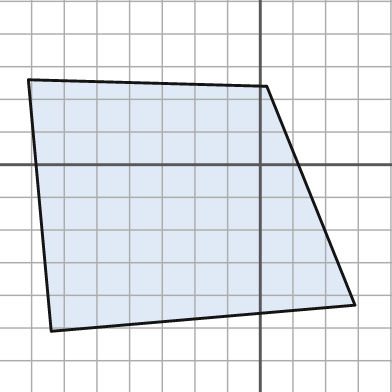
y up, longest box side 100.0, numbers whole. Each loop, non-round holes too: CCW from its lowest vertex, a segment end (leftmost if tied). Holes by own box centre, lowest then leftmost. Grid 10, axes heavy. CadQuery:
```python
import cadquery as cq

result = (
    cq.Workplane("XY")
    .moveTo(-64.0, -51.0)
    .lineTo(29.0, -43.0)
    .lineTo(2.0, 24.0)
    .lineTo(-71.0, 26.0)
    .close()
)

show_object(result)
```